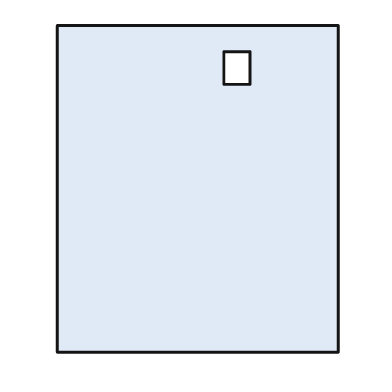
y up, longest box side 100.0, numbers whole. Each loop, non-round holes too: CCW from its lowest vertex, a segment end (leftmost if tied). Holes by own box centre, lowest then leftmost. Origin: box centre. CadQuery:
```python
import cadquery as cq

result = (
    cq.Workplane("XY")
    .moveTo(-43.0, -50.0)
    .lineTo(43.0, -50.0)
    .lineTo(43.0, 50.0)
    .lineTo(-43.0, 50.0)
    .close()
    .moveTo(8.0, 32.0)
    .lineTo(16.0, 32.0)
    .lineTo(16.0, 42.0)
    .lineTo(8.0, 42.0)
    .close()
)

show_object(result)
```